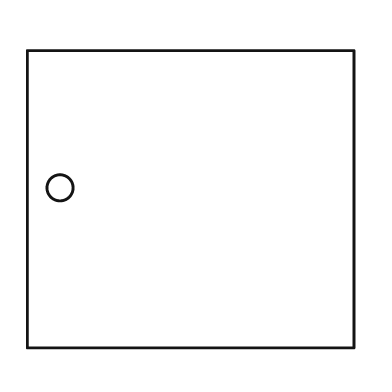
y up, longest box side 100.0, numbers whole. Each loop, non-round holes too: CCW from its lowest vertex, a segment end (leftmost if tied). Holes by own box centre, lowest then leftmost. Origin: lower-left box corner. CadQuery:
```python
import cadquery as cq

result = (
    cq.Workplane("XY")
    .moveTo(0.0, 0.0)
    .lineTo(100.0, 0.0)
    .lineTo(100.0, 91.0)
    .lineTo(0.0, 91.0)
    .close()
    .moveTo(10.0, 49.0)
    .circle(4.0)
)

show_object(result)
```